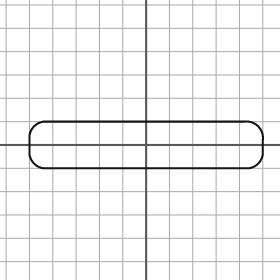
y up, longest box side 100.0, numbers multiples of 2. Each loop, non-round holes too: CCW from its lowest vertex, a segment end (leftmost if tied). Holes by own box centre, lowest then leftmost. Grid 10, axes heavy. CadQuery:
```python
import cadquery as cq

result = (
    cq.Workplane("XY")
    .moveTo(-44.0, -10.0)
    .lineTo(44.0, -10.0)
    .threePointArc((48.0, -8.0), (50.0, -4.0))
    .lineTo(50.0, 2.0)
    .threePointArc((48.0, 8.0), (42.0, 10.0))
    .lineTo(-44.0, 10.0)
    .threePointArc((-48.0, 8.0), (-50.0, 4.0))
    .lineTo(-50.0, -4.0)
    .threePointArc((-48.0, -8.0), (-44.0, -10.0))
    .close()
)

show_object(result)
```